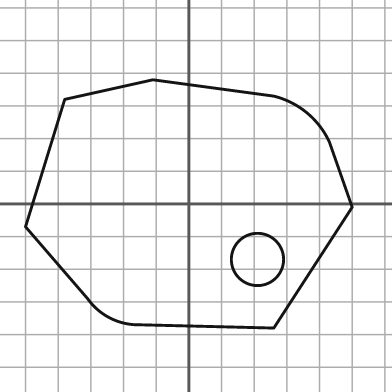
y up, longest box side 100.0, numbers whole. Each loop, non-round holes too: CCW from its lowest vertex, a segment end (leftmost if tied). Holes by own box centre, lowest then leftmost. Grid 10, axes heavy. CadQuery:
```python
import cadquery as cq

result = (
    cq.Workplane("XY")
    .moveTo(26.0, -38.0)
    .lineTo(50.0, -1.0)
    .lineTo(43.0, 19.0)
    .threePointArc((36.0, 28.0), (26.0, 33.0))
    .lineTo(-11.0, 38.0)
    .lineTo(-38.0, 32.0)
    .lineTo(-50.0, -7.0)
    .lineTo(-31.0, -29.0)
    .threePointArc((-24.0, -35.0), (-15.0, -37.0))
    .close()
    .moveTo(21.0, -17.0)
    .circle(8.0)
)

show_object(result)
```